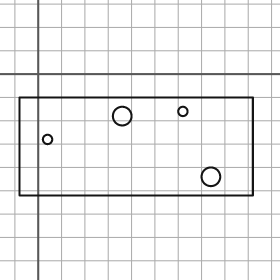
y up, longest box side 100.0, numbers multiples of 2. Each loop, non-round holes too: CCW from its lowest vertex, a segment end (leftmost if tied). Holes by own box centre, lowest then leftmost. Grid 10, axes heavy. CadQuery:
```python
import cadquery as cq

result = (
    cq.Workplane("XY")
    .moveTo(-8.0, -52.0)
    .lineTo(92.0, -52.0)
    .lineTo(92.0, -10.0)
    .lineTo(-8.0, -10.0)
    .close()
    .moveTo(74.0, -44.0)
    .circle(4.0)
    .moveTo(4.0, -28.0)
    .circle(2.0)
    .moveTo(36.0, -18.0)
    .circle(4.0)
    .moveTo(62.0, -16.0)
    .circle(2.0)
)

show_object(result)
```